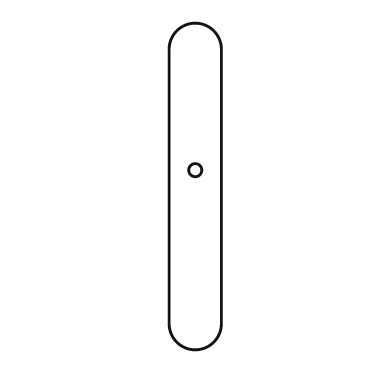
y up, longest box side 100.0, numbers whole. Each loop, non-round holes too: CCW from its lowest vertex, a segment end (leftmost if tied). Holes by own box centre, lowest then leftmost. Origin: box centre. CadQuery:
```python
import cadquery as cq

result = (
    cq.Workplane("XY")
    .moveTo(-8.0, -42.0)
    .threePointArc((0.0, -50.0), (8.0, -42.0))
    .lineTo(8.0, 42.0)
    .threePointArc((0.0, 50.0), (-8.0, 42.0))
    .close()
    .moveTo(0.0, 5.0)
    .circle(2.0)
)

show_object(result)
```